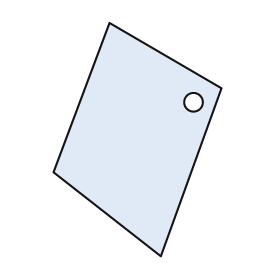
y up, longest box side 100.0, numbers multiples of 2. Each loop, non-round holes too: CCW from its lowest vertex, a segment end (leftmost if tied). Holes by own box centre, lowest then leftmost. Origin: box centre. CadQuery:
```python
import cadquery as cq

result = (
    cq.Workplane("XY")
    .moveTo(10.0, -50.0)
    .lineTo(36.0, 22.0)
    .lineTo(-12.0, 50.0)
    .lineTo(-36.0, -14.0)
    .close()
    .moveTo(24.0, 16.0)
    .circle(4.0)
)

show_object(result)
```